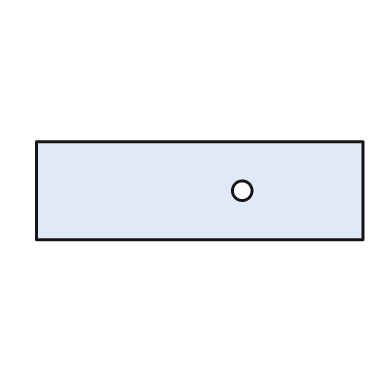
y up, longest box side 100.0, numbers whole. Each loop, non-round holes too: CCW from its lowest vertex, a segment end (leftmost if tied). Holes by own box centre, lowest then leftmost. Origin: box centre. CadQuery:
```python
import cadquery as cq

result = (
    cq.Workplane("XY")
    .moveTo(-50.0, -15.0)
    .lineTo(50.0, -15.0)
    .lineTo(50.0, 15.0)
    .lineTo(-50.0, 15.0)
    .close()
    .moveTo(13.0, 0.0)
    .circle(3.0)
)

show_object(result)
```